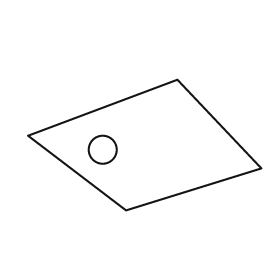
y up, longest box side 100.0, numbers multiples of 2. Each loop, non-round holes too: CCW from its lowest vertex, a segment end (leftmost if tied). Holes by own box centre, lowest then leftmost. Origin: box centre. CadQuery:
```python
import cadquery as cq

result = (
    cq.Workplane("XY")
    .moveTo(-8.0, -28.0)
    .lineTo(50.0, -10.0)
    .lineTo(14.0, 28.0)
    .lineTo(-50.0, 4.0)
    .close()
    .moveTo(-18.0, -2.0)
    .circle(6.0)
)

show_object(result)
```